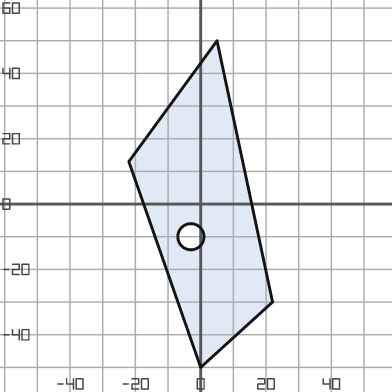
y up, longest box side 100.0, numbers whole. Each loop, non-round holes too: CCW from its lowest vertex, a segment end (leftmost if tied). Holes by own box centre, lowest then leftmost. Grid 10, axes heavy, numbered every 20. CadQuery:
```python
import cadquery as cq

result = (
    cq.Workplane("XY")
    .moveTo(0.0, -50.0)
    .lineTo(22.0, -30.0)
    .lineTo(5.0, 50.0)
    .lineTo(-22.0, 13.0)
    .close()
    .moveTo(-3.0, -10.0)
    .circle(4.0)
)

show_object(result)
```